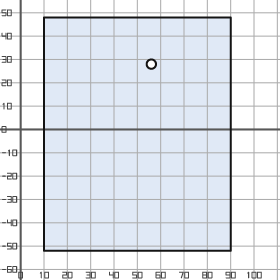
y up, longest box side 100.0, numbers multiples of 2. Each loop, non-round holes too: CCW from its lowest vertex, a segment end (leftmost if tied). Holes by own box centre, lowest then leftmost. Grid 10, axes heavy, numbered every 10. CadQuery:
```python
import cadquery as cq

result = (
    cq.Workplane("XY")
    .moveTo(10.0, -52.0)
    .lineTo(90.0, -52.0)
    .lineTo(90.0, 48.0)
    .lineTo(10.0, 48.0)
    .close()
    .moveTo(56.0, 28.0)
    .circle(2.0)
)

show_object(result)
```